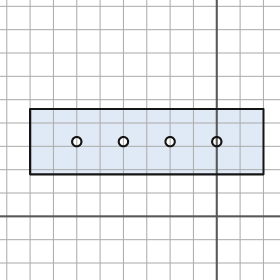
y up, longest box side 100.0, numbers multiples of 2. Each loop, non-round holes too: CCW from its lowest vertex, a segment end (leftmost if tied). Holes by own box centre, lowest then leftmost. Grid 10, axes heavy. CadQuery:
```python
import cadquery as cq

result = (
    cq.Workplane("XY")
    .moveTo(-80.0, 18.0)
    .lineTo(20.0, 18.0)
    .lineTo(20.0, 46.0)
    .lineTo(-80.0, 46.0)
    .close()
    .moveTo(-60.0, 32.0)
    .circle(2.0)
    .moveTo(-40.0, 32.0)
    .circle(2.0)
    .moveTo(-20.0, 32.0)
    .circle(2.0)
    .moveTo(0.0, 32.0)
    .circle(2.0)
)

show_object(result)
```